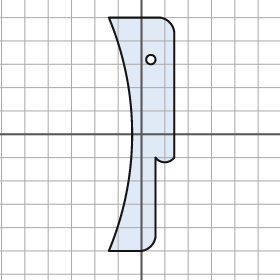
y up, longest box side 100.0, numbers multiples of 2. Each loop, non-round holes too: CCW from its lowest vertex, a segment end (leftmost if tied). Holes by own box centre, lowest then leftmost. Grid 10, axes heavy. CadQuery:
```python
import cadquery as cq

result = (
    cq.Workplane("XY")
    .moveTo(-14.0, -50.0)
    .lineTo(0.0, -50.0)
    .threePointArc((4.0, -48.0), (6.0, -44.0))
    .lineTo(6.0, -10.0)
    .threePointArc((10.0, -12.0), (14.0, -10.0))
    .lineTo(14.0, 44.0)
    .threePointArc((12.0, 48.0), (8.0, 50.0))
    .lineTo(-14.0, 50.0)
    .threePointArc((-4.0, 0.0), (-14.0, -50.0))
    .close()
    .moveTo(4.0, 32.0)
    .circle(2.0)
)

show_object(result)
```